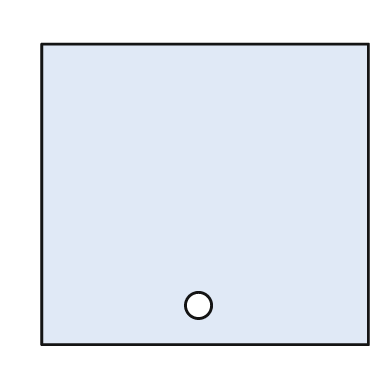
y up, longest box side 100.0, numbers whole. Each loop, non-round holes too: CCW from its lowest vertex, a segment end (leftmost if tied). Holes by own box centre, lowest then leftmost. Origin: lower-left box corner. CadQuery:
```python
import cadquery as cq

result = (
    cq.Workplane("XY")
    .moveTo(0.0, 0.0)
    .lineTo(100.0, 0.0)
    .lineTo(100.0, 92.0)
    .lineTo(0.0, 92.0)
    .close()
    .moveTo(48.0, 12.0)
    .circle(4.0)
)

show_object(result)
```